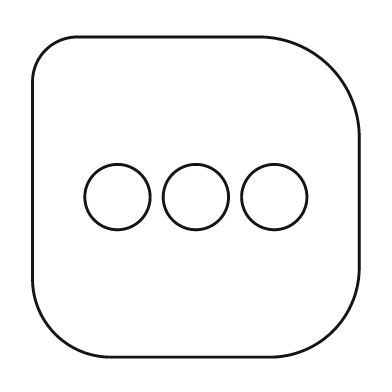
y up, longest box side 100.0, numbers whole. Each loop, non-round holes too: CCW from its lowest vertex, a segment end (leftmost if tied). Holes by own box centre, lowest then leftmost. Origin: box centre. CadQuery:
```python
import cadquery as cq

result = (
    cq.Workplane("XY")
    .moveTo(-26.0, -49.0)
    .lineTo(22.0, -49.0)
    .threePointArc((42.0, -41.0), (50.0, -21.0))
    .lineTo(50.0, 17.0)
    .threePointArc((41.0, 40.0), (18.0, 49.0))
    .lineTo(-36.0, 49.0)
    .threePointArc((-46.0, 45.0), (-50.0, 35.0))
    .lineTo(-50.0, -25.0)
    .threePointArc((-43.0, -42.0), (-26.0, -49.0))
    .close()
    .moveTo(-24.0, 0.0)
    .circle(10.0)
    .moveTo(0.0, 0.0)
    .circle(10.0)
    .moveTo(24.0, 0.0)
    .circle(10.0)
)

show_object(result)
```